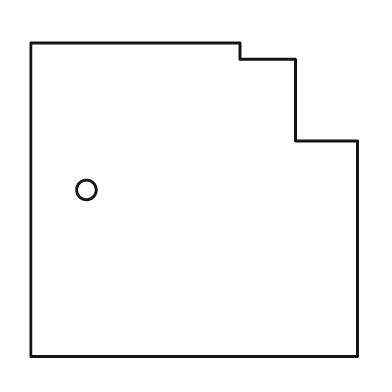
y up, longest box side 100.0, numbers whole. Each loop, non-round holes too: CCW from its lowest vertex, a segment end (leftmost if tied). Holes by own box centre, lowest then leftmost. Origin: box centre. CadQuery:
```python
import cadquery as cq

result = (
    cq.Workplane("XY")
    .moveTo(-50.0, -48.0)
    .lineTo(50.0, -48.0)
    .lineTo(50.0, 18.0)
    .lineTo(31.0, 18.0)
    .lineTo(31.0, 43.0)
    .lineTo(14.0, 43.0)
    .lineTo(14.0, 48.0)
    .lineTo(-50.0, 48.0)
    .close()
    .moveTo(-33.0, 3.0)
    .circle(3.0)
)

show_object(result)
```